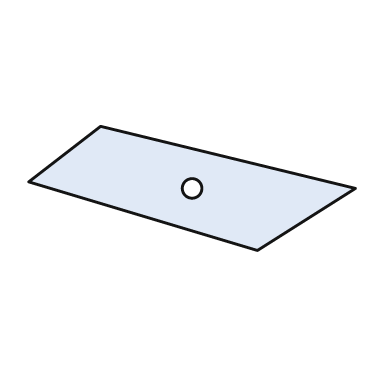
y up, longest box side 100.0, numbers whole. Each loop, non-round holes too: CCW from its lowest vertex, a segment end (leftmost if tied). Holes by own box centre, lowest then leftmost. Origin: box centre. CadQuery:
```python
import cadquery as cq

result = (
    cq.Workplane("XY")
    .moveTo(20.0, -19.0)
    .lineTo(50.0, 0.0)
    .lineTo(-28.0, 19.0)
    .lineTo(-50.0, 2.0)
    .close()
    .moveTo(0.0, 0.0)
    .circle(3.0)
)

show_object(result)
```